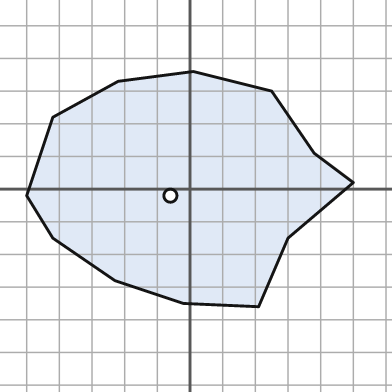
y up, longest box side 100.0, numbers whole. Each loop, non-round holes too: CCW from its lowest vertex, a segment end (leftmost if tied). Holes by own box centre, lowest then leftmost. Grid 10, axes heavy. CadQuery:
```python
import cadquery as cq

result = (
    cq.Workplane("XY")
    .moveTo(21.0, -36.0)
    .lineTo(30.0, -15.0)
    .lineTo(50.0, 2.0)
    .lineTo(38.0, 11.0)
    .lineTo(25.0, 30.0)
    .lineTo(1.0, 36.0)
    .lineTo(-22.0, 33.0)
    .lineTo(-42.0, 22.0)
    .lineTo(-50.0, -2.0)
    .lineTo(-42.0, -15.0)
    .lineTo(-23.0, -28.0)
    .lineTo(-2.0, -35.0)
    .close()
    .moveTo(-6.0, -2.0)
    .circle(2.0)
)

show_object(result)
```